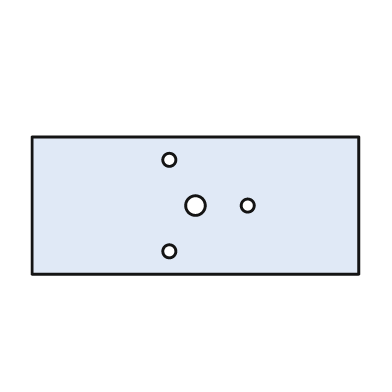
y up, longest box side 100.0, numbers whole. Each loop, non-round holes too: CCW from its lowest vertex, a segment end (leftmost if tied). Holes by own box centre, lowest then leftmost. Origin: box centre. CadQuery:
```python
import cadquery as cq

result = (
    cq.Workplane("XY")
    .moveTo(-50.0, -21.0)
    .lineTo(50.0, -21.0)
    .lineTo(50.0, 21.0)
    .lineTo(-50.0, 21.0)
    .close()
    .moveTo(-8.0, -14.0)
    .circle(2.0)
    .moveTo(0.0, 0.0)
    .circle(3.0)
    .moveTo(16.0, 0.0)
    .circle(2.0)
    .moveTo(-8.0, 14.0)
    .circle(2.0)
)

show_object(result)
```